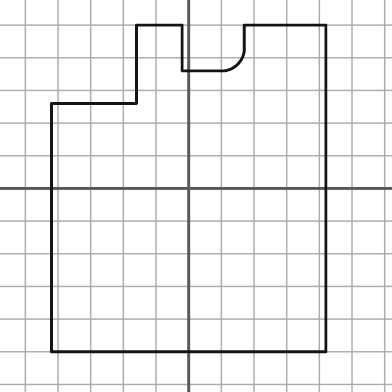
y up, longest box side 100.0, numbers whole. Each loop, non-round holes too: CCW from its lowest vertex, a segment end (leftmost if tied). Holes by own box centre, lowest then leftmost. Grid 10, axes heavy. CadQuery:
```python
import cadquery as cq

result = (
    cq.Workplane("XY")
    .moveTo(-42.0, -50.0)
    .lineTo(42.0, -50.0)
    .lineTo(42.0, 50.0)
    .lineTo(17.0, 50.0)
    .lineTo(17.0, 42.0)
    .threePointArc((15.0, 38.0), (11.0, 36.0))
    .lineTo(-2.0, 36.0)
    .lineTo(-2.0, 50.0)
    .lineTo(-16.0, 50.0)
    .lineTo(-16.0, 26.0)
    .lineTo(-42.0, 26.0)
    .close()
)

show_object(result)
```